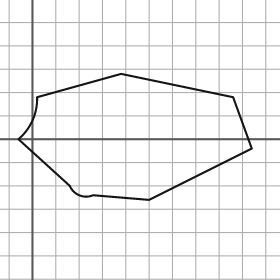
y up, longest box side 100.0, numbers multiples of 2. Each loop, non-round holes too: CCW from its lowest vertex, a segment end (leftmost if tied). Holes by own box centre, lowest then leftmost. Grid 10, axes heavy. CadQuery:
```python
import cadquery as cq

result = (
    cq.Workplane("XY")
    .moveTo(50.0, -26.0)
    .lineTo(94.0, -4.0)
    .lineTo(86.0, 18.0)
    .lineTo(38.0, 28.0)
    .lineTo(2.0, 18.0)
    .threePointArc((0.0, 8.0), (-6.0, 0.0))
    .lineTo(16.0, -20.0)
    .threePointArc((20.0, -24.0), (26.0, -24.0))
    .close()
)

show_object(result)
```